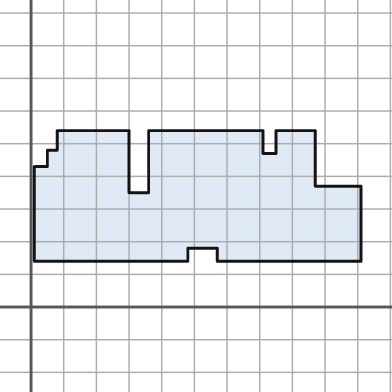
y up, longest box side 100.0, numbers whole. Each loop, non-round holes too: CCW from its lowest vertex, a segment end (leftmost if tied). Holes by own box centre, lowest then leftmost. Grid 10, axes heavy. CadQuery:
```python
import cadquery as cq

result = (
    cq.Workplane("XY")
    .moveTo(1.0, 14.0)
    .lineTo(48.0, 14.0)
    .lineTo(48.0, 18.0)
    .lineTo(57.0, 18.0)
    .lineTo(57.0, 14.0)
    .lineTo(101.0, 14.0)
    .lineTo(101.0, 37.0)
    .lineTo(87.0, 37.0)
    .lineTo(87.0, 54.0)
    .lineTo(75.0, 54.0)
    .lineTo(75.0, 47.0)
    .lineTo(71.0, 47.0)
    .lineTo(71.0, 54.0)
    .lineTo(36.0, 54.0)
    .lineTo(36.0, 35.0)
    .lineTo(30.0, 35.0)
    .lineTo(30.0, 54.0)
    .lineTo(8.0, 54.0)
    .lineTo(8.0, 48.0)
    .lineTo(5.0, 48.0)
    .lineTo(5.0, 43.0)
    .lineTo(1.0, 43.0)
    .close()
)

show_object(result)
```